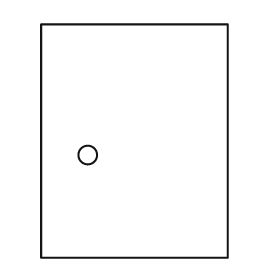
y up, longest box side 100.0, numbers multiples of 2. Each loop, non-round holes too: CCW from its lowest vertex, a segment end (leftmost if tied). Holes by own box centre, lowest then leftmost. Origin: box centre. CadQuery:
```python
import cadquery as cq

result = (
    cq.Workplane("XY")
    .moveTo(-40.0, -50.0)
    .lineTo(40.0, -50.0)
    .lineTo(40.0, 50.0)
    .lineTo(-40.0, 50.0)
    .close()
    .moveTo(-20.0, -6.0)
    .circle(4.0)
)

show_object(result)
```